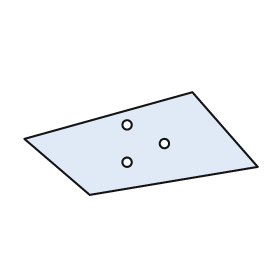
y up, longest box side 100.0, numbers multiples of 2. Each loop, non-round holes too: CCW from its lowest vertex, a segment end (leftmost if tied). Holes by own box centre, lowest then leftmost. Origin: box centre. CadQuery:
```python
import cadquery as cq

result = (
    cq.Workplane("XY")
    .moveTo(-22.0, -22.0)
    .lineTo(50.0, -10.0)
    .lineTo(22.0, 22.0)
    .lineTo(-50.0, 2.0)
    .close()
    .moveTo(-6.0, -8.0)
    .circle(2.0)
    .moveTo(10.0, 0.0)
    .circle(2.0)
    .moveTo(-6.0, 8.0)
    .circle(2.0)
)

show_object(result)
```